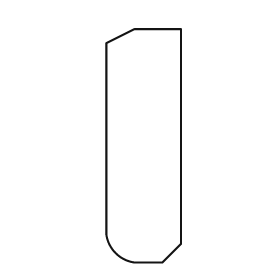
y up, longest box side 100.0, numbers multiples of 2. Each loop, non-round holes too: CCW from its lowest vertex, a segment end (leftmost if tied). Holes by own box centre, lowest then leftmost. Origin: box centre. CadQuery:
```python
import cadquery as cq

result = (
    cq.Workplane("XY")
    .moveTo(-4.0, -50.0)
    .lineTo(8.0, -50.0)
    .lineTo(16.0, -42.0)
    .lineTo(16.0, 50.0)
    .lineTo(-4.0, 50.0)
    .lineTo(-16.0, 44.0)
    .lineTo(-16.0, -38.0)
    .threePointArc((-12.0, -46.0), (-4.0, -50.0))
    .close()
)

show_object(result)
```